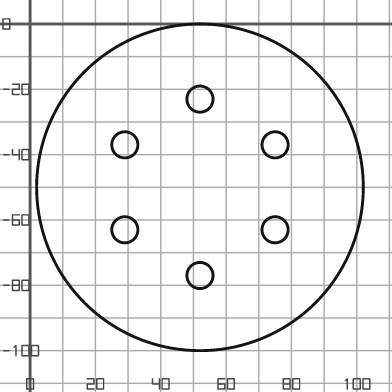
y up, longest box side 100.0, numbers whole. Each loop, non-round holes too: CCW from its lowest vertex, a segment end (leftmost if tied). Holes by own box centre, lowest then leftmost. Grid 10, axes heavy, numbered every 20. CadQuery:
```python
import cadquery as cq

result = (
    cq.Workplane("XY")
    .moveTo(52.0, -50.0)
    .circle(50.0)
    .moveTo(52.0, -77.0)
    .circle(4.0)
    .moveTo(29.0, -63.0)
    .circle(4.0)
    .moveTo(75.0, -63.0)
    .circle(4.0)
    .moveTo(29.0, -37.0)
    .circle(4.0)
    .moveTo(75.0, -37.0)
    .circle(4.0)
    .moveTo(52.0, -23.0)
    .circle(4.0)
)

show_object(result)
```